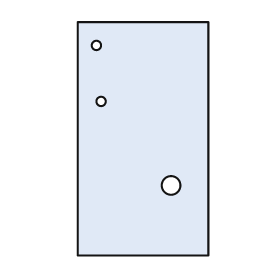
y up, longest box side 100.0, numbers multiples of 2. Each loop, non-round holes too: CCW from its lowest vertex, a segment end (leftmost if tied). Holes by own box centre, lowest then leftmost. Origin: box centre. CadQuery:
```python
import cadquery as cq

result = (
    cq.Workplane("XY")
    .moveTo(-28.0, -50.0)
    .lineTo(28.0, -50.0)
    .lineTo(28.0, 50.0)
    .lineTo(-28.0, 50.0)
    .close()
    .moveTo(12.0, -20.0)
    .circle(4.0)
    .moveTo(-18.0, 16.0)
    .circle(2.0)
    .moveTo(-20.0, 40.0)
    .circle(2.0)
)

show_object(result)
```